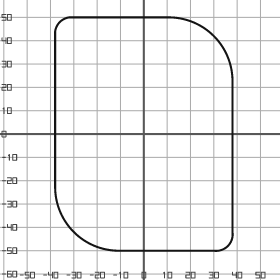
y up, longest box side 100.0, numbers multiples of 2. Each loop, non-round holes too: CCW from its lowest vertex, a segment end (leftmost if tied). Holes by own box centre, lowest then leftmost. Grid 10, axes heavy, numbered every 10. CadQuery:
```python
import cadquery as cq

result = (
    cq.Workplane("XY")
    .moveTo(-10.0, -50.0)
    .lineTo(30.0, -50.0)
    .threePointArc((36.0, -48.0), (38.0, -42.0))
    .lineTo(38.0, 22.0)
    .threePointArc((30.0, 42.0), (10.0, 50.0))
    .lineTo(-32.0, 50.0)
    .threePointArc((-36.0, 48.0), (-38.0, 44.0))
    .lineTo(-38.0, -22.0)
    .threePointArc((-30.0, -42.0), (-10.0, -50.0))
    .close()
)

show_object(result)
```